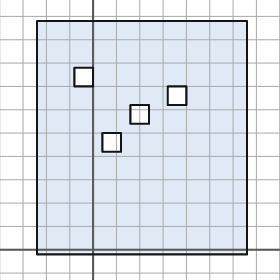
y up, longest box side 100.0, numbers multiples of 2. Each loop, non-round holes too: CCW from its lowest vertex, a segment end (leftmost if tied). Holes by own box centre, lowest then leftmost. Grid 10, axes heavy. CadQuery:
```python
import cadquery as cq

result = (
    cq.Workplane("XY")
    .moveTo(-24.0, -2.0)
    .lineTo(66.0, -2.0)
    .lineTo(66.0, 98.0)
    .lineTo(-24.0, 98.0)
    .close()
    .moveTo(4.0, 42.0)
    .lineTo(12.0, 42.0)
    .lineTo(12.0, 50.0)
    .lineTo(4.0, 50.0)
    .close()
    .moveTo(16.0, 54.0)
    .lineTo(24.0, 54.0)
    .lineTo(24.0, 62.0)
    .lineTo(16.0, 62.0)
    .close()
    .moveTo(32.0, 62.0)
    .lineTo(40.0, 62.0)
    .lineTo(40.0, 70.0)
    .lineTo(32.0, 70.0)
    .close()
    .moveTo(-8.0, 70.0)
    .lineTo(0.0, 70.0)
    .lineTo(0.0, 78.0)
    .lineTo(-8.0, 78.0)
    .close()
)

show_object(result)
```